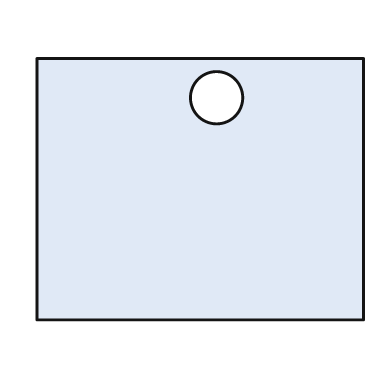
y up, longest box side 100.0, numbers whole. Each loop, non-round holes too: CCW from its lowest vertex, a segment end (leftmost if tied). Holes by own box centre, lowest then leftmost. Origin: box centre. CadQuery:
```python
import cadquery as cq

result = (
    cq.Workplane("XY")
    .moveTo(-50.0, -40.0)
    .lineTo(50.0, -40.0)
    .lineTo(50.0, 40.0)
    .lineTo(-50.0, 40.0)
    .close()
    .moveTo(5.0, 28.0)
    .circle(8.0)
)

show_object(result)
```